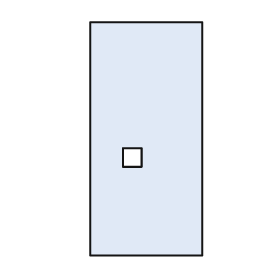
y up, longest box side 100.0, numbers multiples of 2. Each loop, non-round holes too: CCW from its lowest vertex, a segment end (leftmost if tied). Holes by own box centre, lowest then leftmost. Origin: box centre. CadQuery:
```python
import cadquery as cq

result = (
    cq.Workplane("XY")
    .moveTo(-24.0, -50.0)
    .lineTo(24.0, -50.0)
    .lineTo(24.0, 50.0)
    .lineTo(-24.0, 50.0)
    .close()
    .moveTo(-10.0, -12.0)
    .lineTo(-2.0, -12.0)
    .lineTo(-2.0, -4.0)
    .lineTo(-10.0, -4.0)
    .close()
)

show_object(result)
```